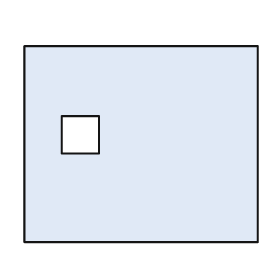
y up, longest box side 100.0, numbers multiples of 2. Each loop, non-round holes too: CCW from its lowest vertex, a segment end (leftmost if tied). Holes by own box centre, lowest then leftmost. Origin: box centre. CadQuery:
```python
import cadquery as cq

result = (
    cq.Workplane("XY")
    .moveTo(-50.0, -42.0)
    .lineTo(50.0, -42.0)
    .lineTo(50.0, 42.0)
    .lineTo(-50.0, 42.0)
    .close()
    .moveTo(-34.0, -4.0)
    .lineTo(-18.0, -4.0)
    .lineTo(-18.0, 12.0)
    .lineTo(-34.0, 12.0)
    .close()
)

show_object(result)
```